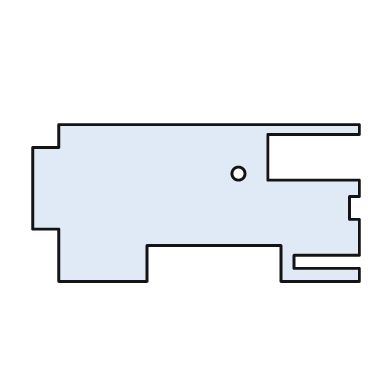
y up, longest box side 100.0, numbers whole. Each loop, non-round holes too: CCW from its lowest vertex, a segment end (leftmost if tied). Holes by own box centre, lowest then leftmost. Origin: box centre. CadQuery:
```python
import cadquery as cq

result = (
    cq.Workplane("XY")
    .moveTo(-42.0, -24.0)
    .lineTo(-15.0, -24.0)
    .lineTo(-15.0, -13.0)
    .lineTo(26.0, -13.0)
    .lineTo(26.0, -24.0)
    .lineTo(50.0, -24.0)
    .lineTo(50.0, -20.0)
    .lineTo(30.0, -20.0)
    .lineTo(30.0, -16.0)
    .lineTo(50.0, -16.0)
    .lineTo(50.0, -5.0)
    .lineTo(47.0, -5.0)
    .lineTo(47.0, 2.0)
    .lineTo(50.0, 2.0)
    .lineTo(50.0, 7.0)
    .lineTo(22.0, 7.0)
    .lineTo(22.0, 21.0)
    .lineTo(50.0, 21.0)
    .lineTo(50.0, 24.0)
    .lineTo(-42.0, 24.0)
    .lineTo(-42.0, 17.0)
    .lineTo(-50.0, 17.0)
    .lineTo(-50.0, -8.0)
    .lineTo(-42.0, -8.0)
    .close()
    .moveTo(13.0, 9.0)
    .circle(2.0)
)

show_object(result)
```